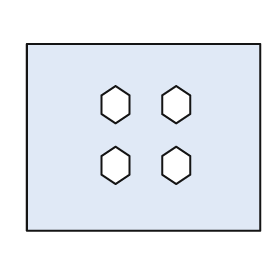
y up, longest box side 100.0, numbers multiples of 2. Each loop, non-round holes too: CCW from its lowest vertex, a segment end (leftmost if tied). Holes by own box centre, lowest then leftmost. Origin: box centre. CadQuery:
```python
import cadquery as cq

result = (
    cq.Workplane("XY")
    .moveTo(-50.0, -40.0)
    .lineTo(50.0, -40.0)
    .lineTo(50.0, 40.0)
    .lineTo(-50.0, 40.0)
    .close()
    .moveTo(-12.0, -20.0)
    .lineTo(-6.0, -16.0)
    .lineTo(-6.0, -8.0)
    .lineTo(-12.0, -4.0)
    .lineTo(-18.0, -8.0)
    .lineTo(-18.0, -16.0)
    .close()
    .moveTo(14.0, -20.0)
    .lineTo(20.0, -16.0)
    .lineTo(20.0, -8.0)
    .lineTo(14.0, -4.0)
    .lineTo(8.0, -8.0)
    .lineTo(8.0, -16.0)
    .close()
    .moveTo(-12.0, 6.0)
    .lineTo(-6.0, 10.0)
    .lineTo(-6.0, 18.0)
    .lineTo(-12.0, 22.0)
    .lineTo(-18.0, 18.0)
    .lineTo(-18.0, 10.0)
    .close()
    .moveTo(14.0, 6.0)
    .lineTo(20.0, 10.0)
    .lineTo(20.0, 18.0)
    .lineTo(14.0, 22.0)
    .lineTo(8.0, 18.0)
    .lineTo(8.0, 10.0)
    .close()
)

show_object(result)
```